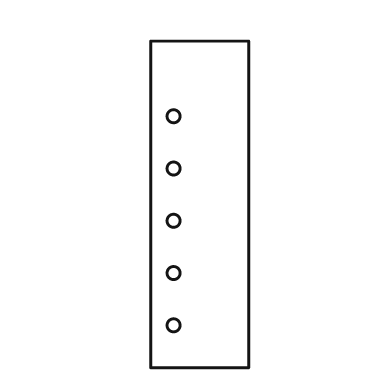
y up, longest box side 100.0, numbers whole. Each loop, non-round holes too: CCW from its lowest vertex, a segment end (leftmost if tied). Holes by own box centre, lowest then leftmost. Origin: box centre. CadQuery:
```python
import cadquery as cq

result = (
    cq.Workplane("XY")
    .moveTo(-15.0, -50.0)
    .lineTo(15.0, -50.0)
    .lineTo(15.0, 50.0)
    .lineTo(-15.0, 50.0)
    .close()
    .moveTo(-8.0, -37.0)
    .circle(2.0)
    .moveTo(-8.0, -21.0)
    .circle(2.0)
    .moveTo(-8.0, -5.0)
    .circle(2.0)
    .moveTo(-8.0, 11.0)
    .circle(2.0)
    .moveTo(-8.0, 27.0)
    .circle(2.0)
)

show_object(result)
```